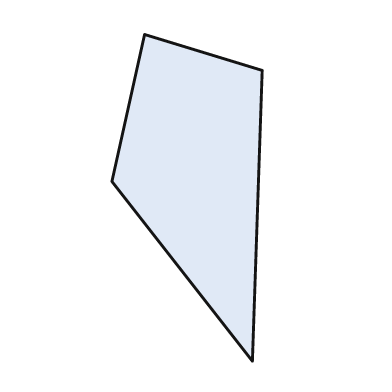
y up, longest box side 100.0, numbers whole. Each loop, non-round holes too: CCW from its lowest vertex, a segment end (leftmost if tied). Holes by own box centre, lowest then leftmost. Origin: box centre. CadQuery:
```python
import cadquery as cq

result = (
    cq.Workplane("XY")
    .moveTo(20.0, -50.0)
    .lineTo(23.0, 39.0)
    .lineTo(-13.0, 50.0)
    .lineTo(-23.0, 5.0)
    .close()
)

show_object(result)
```